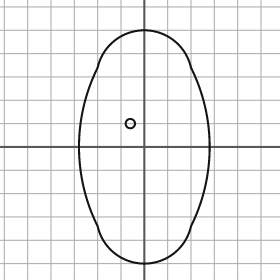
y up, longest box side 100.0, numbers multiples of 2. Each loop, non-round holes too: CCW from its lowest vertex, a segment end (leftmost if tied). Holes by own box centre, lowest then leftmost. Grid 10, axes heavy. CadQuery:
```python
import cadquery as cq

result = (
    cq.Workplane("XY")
    .moveTo(-20.0, -34.0)
    .threePointArc((0.0, -50.0), (20.0, -34.0))
    .threePointArc((28.0, 0.0), (20.0, 34.0))
    .threePointArc((0.0, 50.0), (-20.0, 34.0))
    .threePointArc((-28.0, 0.0), (-20.0, -34.0))
    .close()
    .moveTo(-6.0, 10.0)
    .circle(2.0)
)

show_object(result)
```